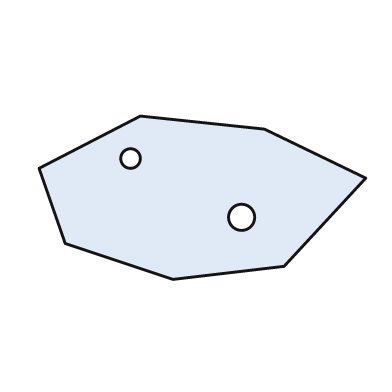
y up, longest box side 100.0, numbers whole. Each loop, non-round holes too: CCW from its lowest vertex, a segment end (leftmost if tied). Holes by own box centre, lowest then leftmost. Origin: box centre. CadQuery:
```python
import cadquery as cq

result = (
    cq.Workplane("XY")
    .moveTo(-9.0, -25.0)
    .lineTo(25.0, -21.0)
    .lineTo(50.0, 6.0)
    .lineTo(19.0, 21.0)
    .lineTo(-19.0, 25.0)
    .lineTo(-50.0, 9.0)
    .lineTo(-42.0, -14.0)
    .close()
    .moveTo(12.0, -6.0)
    .circle(4.0)
    .moveTo(-22.0, 12.0)
    .circle(3.0)
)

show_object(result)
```